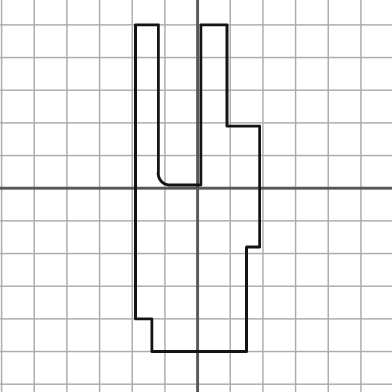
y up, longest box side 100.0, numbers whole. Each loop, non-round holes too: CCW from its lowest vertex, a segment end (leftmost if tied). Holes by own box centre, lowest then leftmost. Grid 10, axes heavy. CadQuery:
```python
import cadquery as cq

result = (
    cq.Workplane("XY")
    .moveTo(-14.0, -50.0)
    .lineTo(15.0, -50.0)
    .lineTo(15.0, -18.0)
    .lineTo(19.0, -18.0)
    .lineTo(19.0, 19.0)
    .lineTo(9.0, 19.0)
    .lineTo(9.0, 50.0)
    .lineTo(1.0, 50.0)
    .lineTo(1.0, 1.0)
    .lineTo(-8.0, 1.0)
    .threePointArc((-11.0, 2.0), (-12.0, 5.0))
    .lineTo(-12.0, 50.0)
    .lineTo(-19.0, 50.0)
    .lineTo(-19.0, -40.0)
    .lineTo(-14.0, -40.0)
    .close()
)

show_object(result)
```